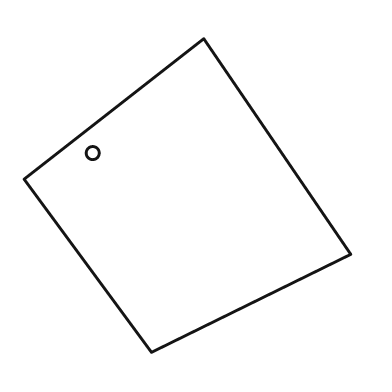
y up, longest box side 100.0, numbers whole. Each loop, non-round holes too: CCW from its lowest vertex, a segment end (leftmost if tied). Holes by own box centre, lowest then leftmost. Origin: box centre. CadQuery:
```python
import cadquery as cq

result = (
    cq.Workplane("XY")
    .moveTo(-11.0, -48.0)
    .lineTo(50.0, -18.0)
    .lineTo(5.0, 48.0)
    .lineTo(-50.0, 5.0)
    .close()
    .moveTo(-29.0, 13.0)
    .circle(2.0)
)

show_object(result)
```